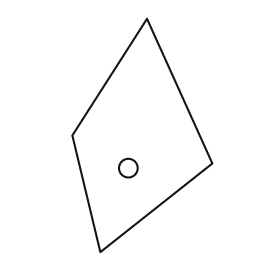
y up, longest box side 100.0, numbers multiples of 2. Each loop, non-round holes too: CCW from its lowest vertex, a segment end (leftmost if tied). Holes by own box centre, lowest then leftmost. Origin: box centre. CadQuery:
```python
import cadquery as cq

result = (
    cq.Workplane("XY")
    .moveTo(-18.0, -50.0)
    .lineTo(30.0, -12.0)
    .lineTo(2.0, 50.0)
    .lineTo(-30.0, 0.0)
    .close()
    .moveTo(-6.0, -14.0)
    .circle(4.0)
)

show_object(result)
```